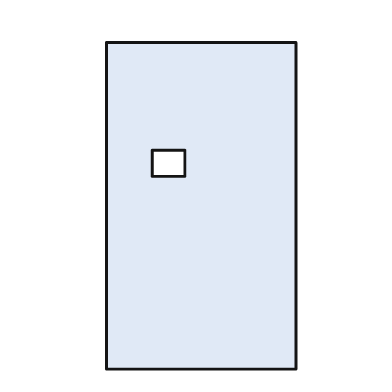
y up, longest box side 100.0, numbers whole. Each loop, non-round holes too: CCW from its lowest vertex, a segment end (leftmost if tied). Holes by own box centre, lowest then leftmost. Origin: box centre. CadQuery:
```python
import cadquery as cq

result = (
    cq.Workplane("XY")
    .moveTo(-29.0, -50.0)
    .lineTo(29.0, -50.0)
    .lineTo(29.0, 50.0)
    .lineTo(-29.0, 50.0)
    .close()
    .moveTo(-15.0, 9.0)
    .lineTo(-5.0, 9.0)
    .lineTo(-5.0, 17.0)
    .lineTo(-15.0, 17.0)
    .close()
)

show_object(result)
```